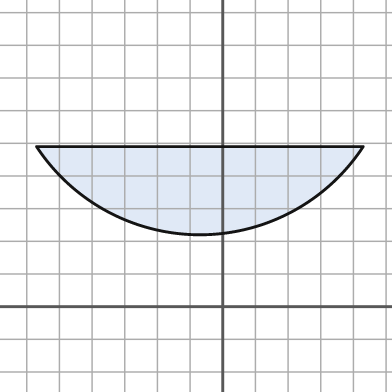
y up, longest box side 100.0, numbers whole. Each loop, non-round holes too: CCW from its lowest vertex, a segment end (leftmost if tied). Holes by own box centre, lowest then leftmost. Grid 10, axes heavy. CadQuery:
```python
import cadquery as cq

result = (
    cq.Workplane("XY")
    .moveTo(-57.0, 49.0)
    .threePointArc((-7.0, 22.0), (43.0, 49.0))
    .close()
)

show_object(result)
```